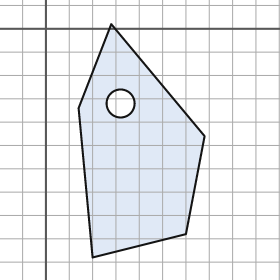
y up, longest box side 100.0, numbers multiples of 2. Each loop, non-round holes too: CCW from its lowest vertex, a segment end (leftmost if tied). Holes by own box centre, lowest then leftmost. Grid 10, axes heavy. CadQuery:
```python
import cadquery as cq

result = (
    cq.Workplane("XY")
    .moveTo(20.0, -98.0)
    .lineTo(60.0, -88.0)
    .lineTo(68.0, -46.0)
    .lineTo(28.0, 2.0)
    .lineTo(14.0, -34.0)
    .close()
    .moveTo(32.0, -32.0)
    .circle(6.0)
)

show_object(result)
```